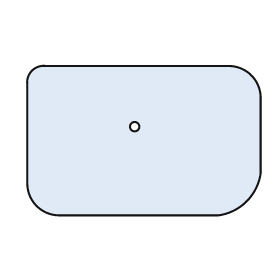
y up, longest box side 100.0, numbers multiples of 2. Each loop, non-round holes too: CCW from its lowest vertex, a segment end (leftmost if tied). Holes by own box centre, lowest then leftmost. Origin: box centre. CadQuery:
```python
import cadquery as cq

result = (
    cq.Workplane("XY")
    .moveTo(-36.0, -32.0)
    .lineTo(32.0, -32.0)
    .threePointArc((44.0, -26.0), (50.0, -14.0))
    .lineTo(50.0, 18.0)
    .threePointArc((46.0, 28.0), (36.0, 32.0))
    .lineTo(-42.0, 32.0)
    .threePointArc((-48.0, 30.0), (-50.0, 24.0))
    .lineTo(-50.0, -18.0)
    .threePointArc((-46.0, -28.0), (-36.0, -32.0))
    .close()
    .moveTo(-4.0, 6.0)
    .circle(2.0)
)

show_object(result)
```